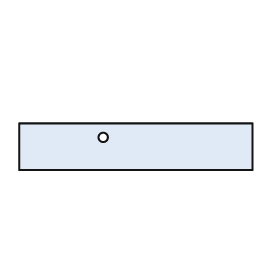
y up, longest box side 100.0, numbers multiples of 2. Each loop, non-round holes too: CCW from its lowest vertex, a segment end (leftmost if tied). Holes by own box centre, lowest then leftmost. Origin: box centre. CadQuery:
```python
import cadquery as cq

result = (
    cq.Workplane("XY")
    .moveTo(-50.0, -10.0)
    .lineTo(50.0, -10.0)
    .lineTo(50.0, 10.0)
    .lineTo(-50.0, 10.0)
    .close()
    .moveTo(-14.0, 4.0)
    .circle(2.0)
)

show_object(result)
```